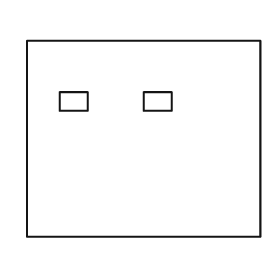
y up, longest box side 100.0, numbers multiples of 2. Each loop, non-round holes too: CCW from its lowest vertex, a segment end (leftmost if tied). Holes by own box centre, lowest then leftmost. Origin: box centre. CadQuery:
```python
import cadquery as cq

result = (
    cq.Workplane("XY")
    .moveTo(-50.0, -42.0)
    .lineTo(50.0, -42.0)
    .lineTo(50.0, 42.0)
    .lineTo(-50.0, 42.0)
    .close()
    .moveTo(-36.0, 12.0)
    .lineTo(-24.0, 12.0)
    .lineTo(-24.0, 20.0)
    .lineTo(-36.0, 20.0)
    .close()
    .moveTo(0.0, 12.0)
    .lineTo(12.0, 12.0)
    .lineTo(12.0, 20.0)
    .lineTo(0.0, 20.0)
    .close()
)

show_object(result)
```